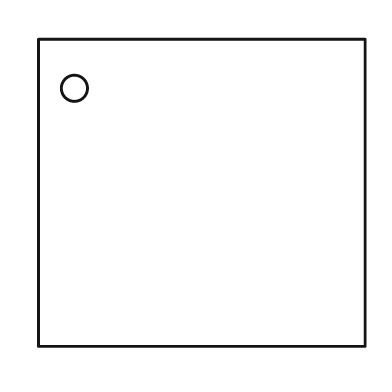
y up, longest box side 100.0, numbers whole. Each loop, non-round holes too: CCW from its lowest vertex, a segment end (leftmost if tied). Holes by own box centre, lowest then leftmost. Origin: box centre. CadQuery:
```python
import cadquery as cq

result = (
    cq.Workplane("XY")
    .moveTo(-50.0, -47.0)
    .lineTo(50.0, -47.0)
    .lineTo(50.0, 47.0)
    .lineTo(-50.0, 47.0)
    .close()
    .moveTo(-39.0, 32.0)
    .circle(4.0)
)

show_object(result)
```